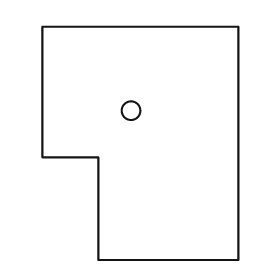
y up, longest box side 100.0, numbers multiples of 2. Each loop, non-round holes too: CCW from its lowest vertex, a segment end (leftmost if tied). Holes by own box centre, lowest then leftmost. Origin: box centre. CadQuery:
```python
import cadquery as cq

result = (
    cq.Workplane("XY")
    .moveTo(-18.0, -50.0)
    .lineTo(42.0, -50.0)
    .lineTo(42.0, 50.0)
    .lineTo(-42.0, 50.0)
    .lineTo(-42.0, -6.0)
    .lineTo(-18.0, -6.0)
    .close()
    .moveTo(-4.0, 14.0)
    .circle(4.0)
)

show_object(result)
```